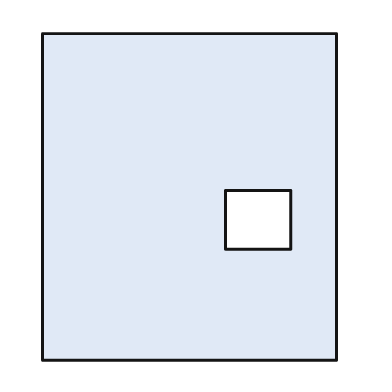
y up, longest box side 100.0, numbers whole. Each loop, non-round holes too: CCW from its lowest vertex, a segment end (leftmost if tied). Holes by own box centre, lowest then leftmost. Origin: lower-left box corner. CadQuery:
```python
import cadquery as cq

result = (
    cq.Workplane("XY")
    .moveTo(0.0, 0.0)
    .lineTo(90.0, 0.0)
    .lineTo(90.0, 100.0)
    .lineTo(0.0, 100.0)
    .close()
    .moveTo(56.0, 34.0)
    .lineTo(76.0, 34.0)
    .lineTo(76.0, 52.0)
    .lineTo(56.0, 52.0)
    .close()
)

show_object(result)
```